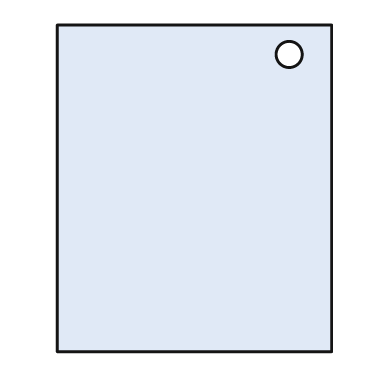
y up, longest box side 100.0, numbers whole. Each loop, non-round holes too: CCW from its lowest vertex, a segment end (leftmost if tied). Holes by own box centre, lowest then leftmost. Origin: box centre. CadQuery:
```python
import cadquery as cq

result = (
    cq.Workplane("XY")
    .moveTo(-42.0, -50.0)
    .lineTo(42.0, -50.0)
    .lineTo(42.0, 50.0)
    .lineTo(-42.0, 50.0)
    .close()
    .moveTo(29.0, 41.0)
    .circle(4.0)
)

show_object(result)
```